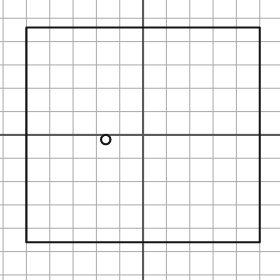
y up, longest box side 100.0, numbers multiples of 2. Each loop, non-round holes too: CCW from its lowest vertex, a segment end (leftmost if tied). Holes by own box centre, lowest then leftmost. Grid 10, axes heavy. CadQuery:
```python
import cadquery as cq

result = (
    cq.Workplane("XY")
    .moveTo(-50.0, -46.0)
    .lineTo(50.0, -46.0)
    .lineTo(50.0, 46.0)
    .lineTo(-50.0, 46.0)
    .close()
    .moveTo(-16.0, -2.0)
    .circle(2.0)
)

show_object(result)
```